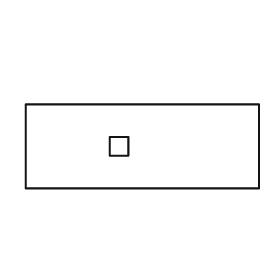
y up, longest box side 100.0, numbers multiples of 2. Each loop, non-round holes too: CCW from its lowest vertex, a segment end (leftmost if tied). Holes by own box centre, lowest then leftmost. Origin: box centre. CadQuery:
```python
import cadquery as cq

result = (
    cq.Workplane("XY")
    .moveTo(-50.0, -18.0)
    .lineTo(50.0, -18.0)
    .lineTo(50.0, 18.0)
    .lineTo(-50.0, 18.0)
    .close()
    .moveTo(-14.0, -4.0)
    .lineTo(-6.0, -4.0)
    .lineTo(-6.0, 4.0)
    .lineTo(-14.0, 4.0)
    .close()
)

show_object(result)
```